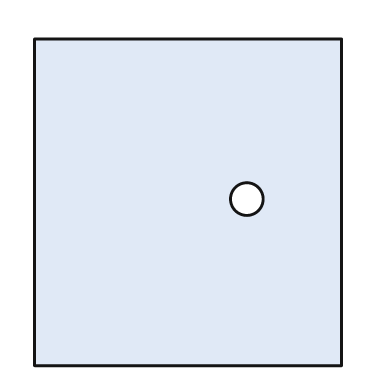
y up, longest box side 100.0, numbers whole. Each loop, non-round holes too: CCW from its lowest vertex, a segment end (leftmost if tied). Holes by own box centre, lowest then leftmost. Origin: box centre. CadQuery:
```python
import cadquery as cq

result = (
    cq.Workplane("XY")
    .moveTo(-47.0, -50.0)
    .lineTo(47.0, -50.0)
    .lineTo(47.0, 50.0)
    .lineTo(-47.0, 50.0)
    .close()
    .moveTo(18.0, 1.0)
    .circle(5.0)
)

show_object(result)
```